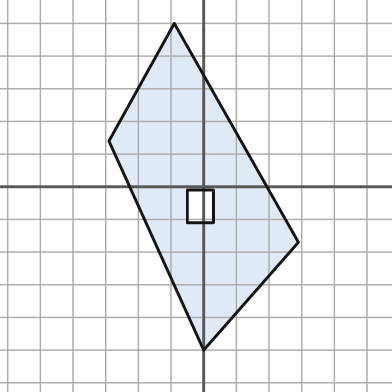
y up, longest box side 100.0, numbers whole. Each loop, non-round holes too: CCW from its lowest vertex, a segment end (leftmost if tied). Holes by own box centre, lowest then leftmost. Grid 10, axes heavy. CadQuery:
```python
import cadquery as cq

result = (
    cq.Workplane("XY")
    .moveTo(0.0, -50.0)
    .lineTo(29.0, -17.0)
    .lineTo(-9.0, 50.0)
    .lineTo(-29.0, 14.0)
    .close()
    .moveTo(-5.0, -11.0)
    .lineTo(3.0, -11.0)
    .lineTo(3.0, -1.0)
    .lineTo(-5.0, -1.0)
    .close()
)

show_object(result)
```